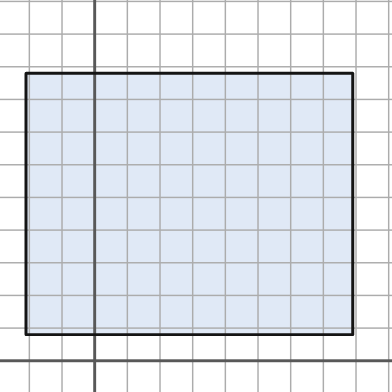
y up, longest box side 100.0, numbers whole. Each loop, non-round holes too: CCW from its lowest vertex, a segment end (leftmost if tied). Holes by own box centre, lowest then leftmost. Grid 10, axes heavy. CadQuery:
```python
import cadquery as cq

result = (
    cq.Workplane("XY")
    .moveTo(-21.0, 8.0)
    .lineTo(79.0, 8.0)
    .lineTo(79.0, 88.0)
    .lineTo(-21.0, 88.0)
    .close()
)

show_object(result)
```